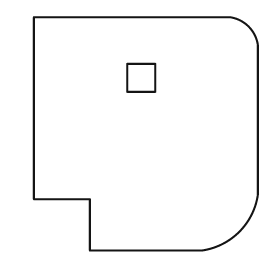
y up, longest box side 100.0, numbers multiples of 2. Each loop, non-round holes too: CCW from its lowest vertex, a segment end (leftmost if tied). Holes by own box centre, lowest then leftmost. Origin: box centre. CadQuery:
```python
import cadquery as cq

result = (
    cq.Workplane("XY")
    .moveTo(-24.0, -50.0)
    .lineTo(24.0, -50.0)
    .threePointArc((40.0, -42.0), (48.0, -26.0))
    .lineTo(48.0, 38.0)
    .threePointArc((44.0, 46.0), (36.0, 50.0))
    .lineTo(-48.0, 50.0)
    .lineTo(-48.0, -28.0)
    .lineTo(-24.0, -28.0)
    .close()
    .moveTo(-8.0, 18.0)
    .lineTo(4.0, 18.0)
    .lineTo(4.0, 30.0)
    .lineTo(-8.0, 30.0)
    .close()
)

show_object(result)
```